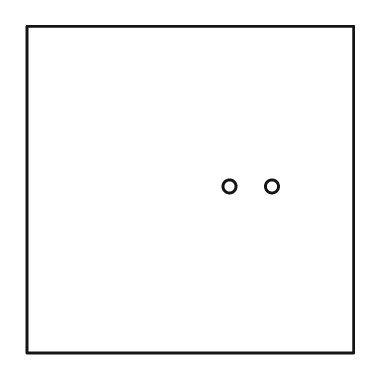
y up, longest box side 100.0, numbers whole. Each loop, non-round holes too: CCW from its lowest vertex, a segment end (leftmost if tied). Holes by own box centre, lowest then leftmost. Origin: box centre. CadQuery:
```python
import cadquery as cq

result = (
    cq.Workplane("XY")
    .moveTo(-50.0, -50.0)
    .lineTo(50.0, -50.0)
    .lineTo(50.0, 50.0)
    .lineTo(-50.0, 50.0)
    .close()
    .moveTo(12.0, 1.0)
    .circle(2.0)
    .moveTo(25.0, 1.0)
    .circle(2.0)
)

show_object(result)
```